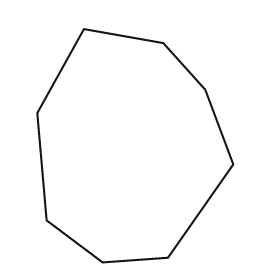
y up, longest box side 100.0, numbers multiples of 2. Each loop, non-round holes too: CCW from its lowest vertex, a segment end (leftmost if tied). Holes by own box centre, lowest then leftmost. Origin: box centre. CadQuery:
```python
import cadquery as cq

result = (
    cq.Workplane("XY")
    .moveTo(-14.0, -50.0)
    .lineTo(14.0, -48.0)
    .lineTo(42.0, -8.0)
    .lineTo(30.0, 24.0)
    .lineTo(12.0, 44.0)
    .lineTo(-22.0, 50.0)
    .lineTo(-42.0, 14.0)
    .lineTo(-38.0, -32.0)
    .close()
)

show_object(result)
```